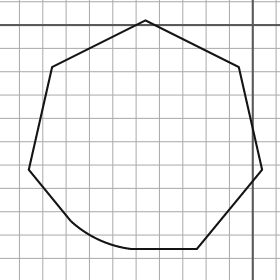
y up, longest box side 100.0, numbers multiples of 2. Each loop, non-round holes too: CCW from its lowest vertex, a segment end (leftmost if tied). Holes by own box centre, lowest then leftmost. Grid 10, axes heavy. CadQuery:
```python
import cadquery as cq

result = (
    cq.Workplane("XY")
    .moveTo(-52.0, -96.0)
    .lineTo(-24.0, -96.0)
    .lineTo(4.0, -62.0)
    .lineTo(-6.0, -18.0)
    .lineTo(-46.0, 2.0)
    .lineTo(-86.0, -18.0)
    .lineTo(-96.0, -62.0)
    .lineTo(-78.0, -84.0)
    .threePointArc((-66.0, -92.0), (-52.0, -96.0))
    .close()
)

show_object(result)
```